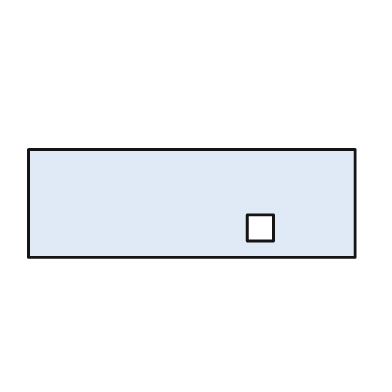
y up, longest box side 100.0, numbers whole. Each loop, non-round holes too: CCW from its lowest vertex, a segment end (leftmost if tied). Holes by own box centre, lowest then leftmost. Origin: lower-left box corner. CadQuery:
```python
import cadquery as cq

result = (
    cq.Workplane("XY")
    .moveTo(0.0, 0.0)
    .lineTo(100.0, 0.0)
    .lineTo(100.0, 33.0)
    .lineTo(0.0, 33.0)
    .close()
    .moveTo(67.0, 5.0)
    .lineTo(75.0, 5.0)
    .lineTo(75.0, 13.0)
    .lineTo(67.0, 13.0)
    .close()
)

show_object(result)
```